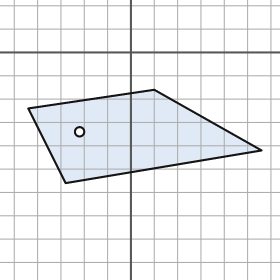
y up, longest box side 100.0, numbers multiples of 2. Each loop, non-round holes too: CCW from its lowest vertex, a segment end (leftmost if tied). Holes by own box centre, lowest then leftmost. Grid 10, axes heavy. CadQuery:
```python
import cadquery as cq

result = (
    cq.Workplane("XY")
    .moveTo(-28.0, -56.0)
    .lineTo(56.0, -42.0)
    .lineTo(10.0, -16.0)
    .lineTo(-44.0, -24.0)
    .close()
    .moveTo(-22.0, -34.0)
    .circle(2.0)
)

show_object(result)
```